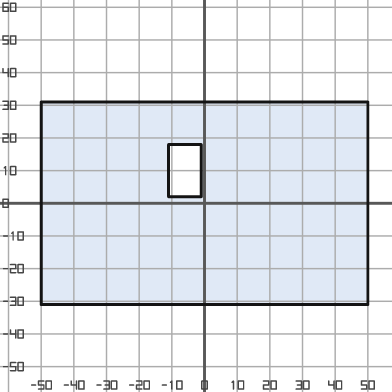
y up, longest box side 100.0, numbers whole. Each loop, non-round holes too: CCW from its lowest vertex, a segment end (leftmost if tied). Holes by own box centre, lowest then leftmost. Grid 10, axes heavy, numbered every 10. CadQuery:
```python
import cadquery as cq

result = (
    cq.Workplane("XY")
    .moveTo(-50.0, -31.0)
    .lineTo(50.0, -31.0)
    .lineTo(50.0, 31.0)
    .lineTo(-50.0, 31.0)
    .close()
    .moveTo(-11.0, 2.0)
    .lineTo(-1.0, 2.0)
    .lineTo(-1.0, 18.0)
    .lineTo(-11.0, 18.0)
    .close()
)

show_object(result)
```